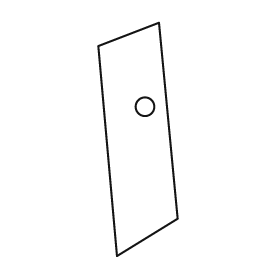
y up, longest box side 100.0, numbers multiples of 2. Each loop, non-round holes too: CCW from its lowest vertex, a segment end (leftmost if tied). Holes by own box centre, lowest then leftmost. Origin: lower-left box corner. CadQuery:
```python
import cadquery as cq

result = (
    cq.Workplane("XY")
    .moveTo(8.0, 0.0)
    .lineTo(34.0, 16.0)
    .lineTo(26.0, 100.0)
    .lineTo(0.0, 90.0)
    .close()
    .moveTo(20.0, 64.0)
    .circle(4.0)
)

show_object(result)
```